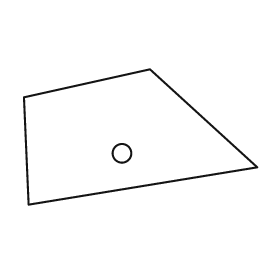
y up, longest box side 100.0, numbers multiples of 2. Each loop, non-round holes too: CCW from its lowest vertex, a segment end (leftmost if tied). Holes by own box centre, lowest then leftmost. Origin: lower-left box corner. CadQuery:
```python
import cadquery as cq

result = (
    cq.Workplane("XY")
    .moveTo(2.0, 0.0)
    .lineTo(100.0, 16.0)
    .lineTo(54.0, 58.0)
    .lineTo(0.0, 46.0)
    .close()
    .moveTo(42.0, 22.0)
    .circle(4.0)
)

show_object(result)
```